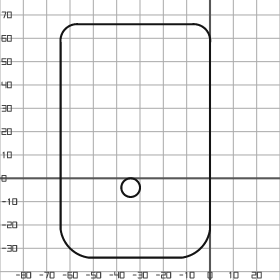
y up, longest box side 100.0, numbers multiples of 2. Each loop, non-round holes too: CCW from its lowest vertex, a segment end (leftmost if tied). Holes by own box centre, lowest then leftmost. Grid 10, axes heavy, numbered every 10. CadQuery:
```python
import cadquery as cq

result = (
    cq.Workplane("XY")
    .moveTo(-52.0, -34.0)
    .lineTo(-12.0, -34.0)
    .threePointArc((-4.0, -30.0), (0.0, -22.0))
    .lineTo(0.0, 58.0)
    .threePointArc((-2.0, 64.0), (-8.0, 66.0))
    .lineTo(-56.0, 66.0)
    .threePointArc((-62.0, 64.0), (-64.0, 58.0))
    .lineTo(-64.0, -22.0)
    .threePointArc((-60.0, -30.0), (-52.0, -34.0))
    .close()
    .moveTo(-34.0, -4.0)
    .circle(4.0)
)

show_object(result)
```